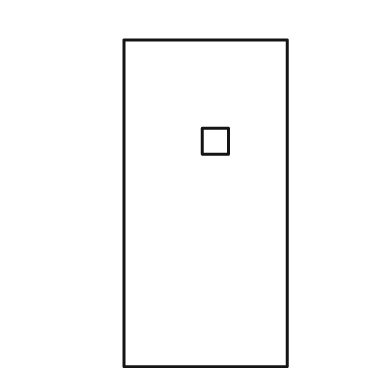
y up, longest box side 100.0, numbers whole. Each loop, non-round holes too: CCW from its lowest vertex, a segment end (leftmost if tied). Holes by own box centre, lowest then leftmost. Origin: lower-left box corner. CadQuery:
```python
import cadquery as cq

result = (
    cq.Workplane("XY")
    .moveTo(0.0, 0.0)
    .lineTo(50.0, 0.0)
    .lineTo(50.0, 100.0)
    .lineTo(0.0, 100.0)
    .close()
    .moveTo(24.0, 65.0)
    .lineTo(32.0, 65.0)
    .lineTo(32.0, 73.0)
    .lineTo(24.0, 73.0)
    .close()
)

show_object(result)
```